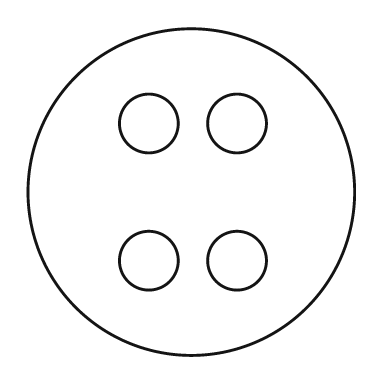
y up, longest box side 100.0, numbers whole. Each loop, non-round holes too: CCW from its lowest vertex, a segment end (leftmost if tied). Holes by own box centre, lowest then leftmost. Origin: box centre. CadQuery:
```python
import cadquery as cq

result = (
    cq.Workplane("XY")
    .moveTo(0.0, 0.0)
    .circle(50.0)
    .moveTo(-13.0, -21.0)
    .circle(9.0)
    .moveTo(14.0, -21.0)
    .circle(9.0)
    .moveTo(-13.0, 21.0)
    .circle(9.0)
    .moveTo(14.0, 21.0)
    .circle(9.0)
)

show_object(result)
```